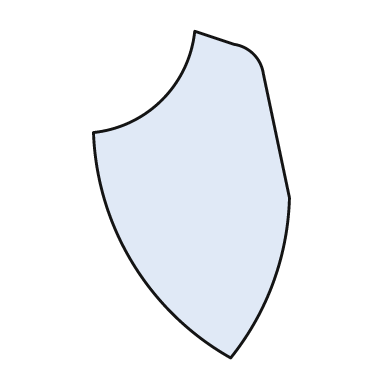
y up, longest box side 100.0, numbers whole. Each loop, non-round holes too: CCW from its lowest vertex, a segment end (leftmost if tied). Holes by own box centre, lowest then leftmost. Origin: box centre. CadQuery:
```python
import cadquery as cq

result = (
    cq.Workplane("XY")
    .moveTo(12.0, -50.0)
    .threePointArc((25.0, -27.0), (30.0, -1.0))
    .lineTo(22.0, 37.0)
    .threePointArc((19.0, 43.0), (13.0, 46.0))
    .lineTo(1.0, 50.0)
    .threePointArc((-9.0, 29.0), (-30.0, 19.0))
    .threePointArc((-18.0, -21.0), (12.0, -50.0))
    .close()
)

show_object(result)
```